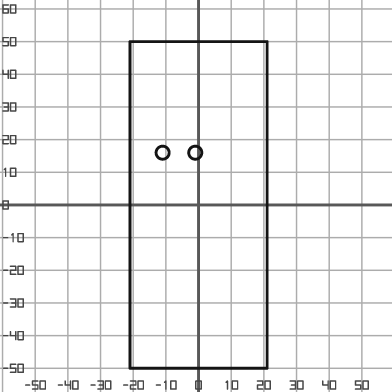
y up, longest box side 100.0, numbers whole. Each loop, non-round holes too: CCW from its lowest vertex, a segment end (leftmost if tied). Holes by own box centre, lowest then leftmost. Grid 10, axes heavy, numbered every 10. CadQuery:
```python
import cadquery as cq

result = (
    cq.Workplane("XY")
    .moveTo(-21.0, -50.0)
    .lineTo(21.0, -50.0)
    .lineTo(21.0, 50.0)
    .lineTo(-21.0, 50.0)
    .close()
    .moveTo(-11.0, 16.0)
    .circle(2.0)
    .moveTo(-1.0, 16.0)
    .circle(2.0)
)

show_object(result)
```